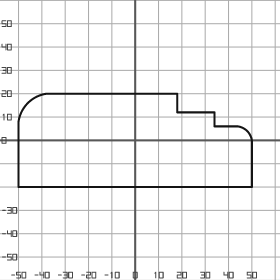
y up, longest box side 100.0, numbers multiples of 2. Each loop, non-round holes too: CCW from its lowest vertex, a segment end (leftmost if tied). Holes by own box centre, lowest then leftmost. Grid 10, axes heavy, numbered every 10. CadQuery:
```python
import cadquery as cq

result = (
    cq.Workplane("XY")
    .moveTo(-50.0, -20.0)
    .lineTo(50.0, -20.0)
    .lineTo(50.0, 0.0)
    .threePointArc((48.0, 4.0), (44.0, 6.0))
    .lineTo(34.0, 6.0)
    .lineTo(34.0, 12.0)
    .lineTo(18.0, 12.0)
    .lineTo(18.0, 20.0)
    .lineTo(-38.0, 20.0)
    .threePointArc((-46.0, 16.0), (-50.0, 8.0))
    .close()
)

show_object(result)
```